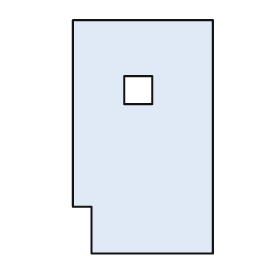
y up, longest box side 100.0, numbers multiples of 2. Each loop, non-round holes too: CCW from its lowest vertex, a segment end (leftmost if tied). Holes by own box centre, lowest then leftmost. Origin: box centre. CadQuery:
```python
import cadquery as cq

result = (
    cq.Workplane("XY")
    .moveTo(-22.0, -50.0)
    .lineTo(30.0, -50.0)
    .lineTo(30.0, 50.0)
    .lineTo(-30.0, 50.0)
    .lineTo(-30.0, -30.0)
    .lineTo(-22.0, -30.0)
    .close()
    .moveTo(-8.0, 14.0)
    .lineTo(4.0, 14.0)
    .lineTo(4.0, 26.0)
    .lineTo(-8.0, 26.0)
    .close()
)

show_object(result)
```